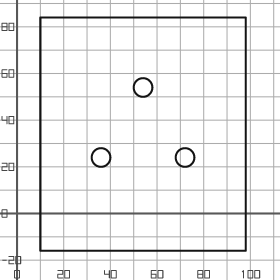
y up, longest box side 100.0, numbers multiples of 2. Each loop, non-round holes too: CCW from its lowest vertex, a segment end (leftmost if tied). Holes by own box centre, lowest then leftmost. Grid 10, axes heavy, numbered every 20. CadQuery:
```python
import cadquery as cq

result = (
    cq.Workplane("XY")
    .moveTo(10.0, -16.0)
    .lineTo(98.0, -16.0)
    .lineTo(98.0, 84.0)
    .lineTo(10.0, 84.0)
    .close()
    .moveTo(36.0, 24.0)
    .circle(4.0)
    .moveTo(72.0, 24.0)
    .circle(4.0)
    .moveTo(54.0, 54.0)
    .circle(4.0)
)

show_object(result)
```